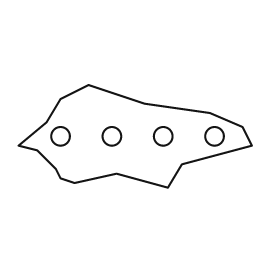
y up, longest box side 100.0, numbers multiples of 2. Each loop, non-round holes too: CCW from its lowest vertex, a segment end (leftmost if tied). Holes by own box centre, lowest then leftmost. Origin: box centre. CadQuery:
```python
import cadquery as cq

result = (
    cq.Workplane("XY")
    .moveTo(14.0, -22.0)
    .lineTo(20.0, -12.0)
    .lineTo(50.0, -4.0)
    .lineTo(46.0, 4.0)
    .lineTo(32.0, 10.0)
    .lineTo(4.0, 14.0)
    .lineTo(-20.0, 22.0)
    .lineTo(-32.0, 16.0)
    .lineTo(-38.0, 6.0)
    .lineTo(-50.0, -4.0)
    .lineTo(-42.0, -6.0)
    .lineTo(-34.0, -14.0)
    .lineTo(-32.0, -18.0)
    .lineTo(-26.0, -20.0)
    .lineTo(-8.0, -16.0)
    .close()
    .moveTo(-32.0, 0.0)
    .circle(4.0)
    .moveTo(-10.0, 0.0)
    .circle(4.0)
    .moveTo(12.0, 0.0)
    .circle(4.0)
    .moveTo(34.0, 0.0)
    .circle(4.0)
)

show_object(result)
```